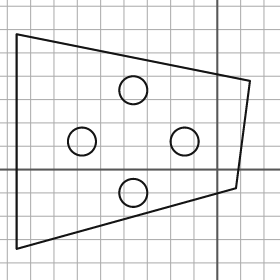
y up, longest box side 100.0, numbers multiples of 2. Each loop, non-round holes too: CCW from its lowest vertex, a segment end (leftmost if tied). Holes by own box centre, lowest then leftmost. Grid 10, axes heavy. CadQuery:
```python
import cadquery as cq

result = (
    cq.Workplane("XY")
    .moveTo(-86.0, -34.0)
    .lineTo(8.0, -8.0)
    .lineTo(14.0, 38.0)
    .lineTo(-86.0, 58.0)
    .close()
    .moveTo(-36.0, -10.0)
    .circle(6.0)
    .moveTo(-58.0, 12.0)
    .circle(6.0)
    .moveTo(-14.0, 12.0)
    .circle(6.0)
    .moveTo(-36.0, 34.0)
    .circle(6.0)
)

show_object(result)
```